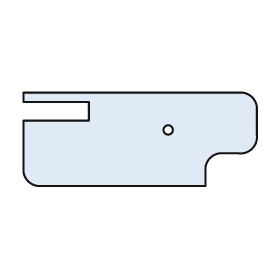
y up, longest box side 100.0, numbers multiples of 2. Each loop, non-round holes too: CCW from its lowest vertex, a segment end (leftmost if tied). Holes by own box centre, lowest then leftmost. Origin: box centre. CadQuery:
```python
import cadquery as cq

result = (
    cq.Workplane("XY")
    .moveTo(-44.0, -20.0)
    .lineTo(28.0, -20.0)
    .lineTo(28.0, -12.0)
    .threePointArc((30.0, -8.0), (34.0, -6.0))
    .lineTo(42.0, -6.0)
    .threePointArc((48.0, -4.0), (50.0, 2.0))
    .lineTo(50.0, 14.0)
    .threePointArc((48.0, 18.0), (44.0, 20.0))
    .lineTo(-50.0, 20.0)
    .lineTo(-50.0, 16.0)
    .lineTo(-22.0, 16.0)
    .lineTo(-22.0, 8.0)
    .lineTo(-50.0, 8.0)
    .lineTo(-50.0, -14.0)
    .threePointArc((-48.0, -18.0), (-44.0, -20.0))
    .close()
    .moveTo(12.0, 4.0)
    .circle(2.0)
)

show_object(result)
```